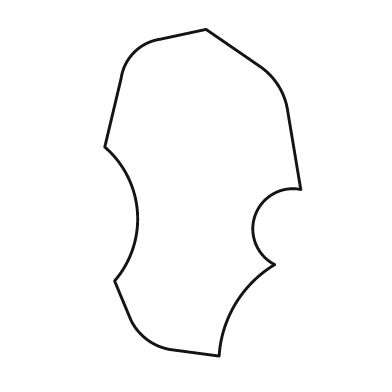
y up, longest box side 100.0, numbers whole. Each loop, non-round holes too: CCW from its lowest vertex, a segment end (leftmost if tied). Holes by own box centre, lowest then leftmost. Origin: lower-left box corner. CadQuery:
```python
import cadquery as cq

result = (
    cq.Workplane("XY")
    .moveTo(35.0, 0.0)
    .threePointArc((40.0, 16.0), (52.0, 28.0))
    .threePointArc((46.0, 43.0), (60.0, 51.0))
    .lineTo(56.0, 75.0)
    .threePointArc((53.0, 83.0), (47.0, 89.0))
    .lineTo(31.0, 100.0)
    .lineTo(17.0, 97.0)
    .threePointArc((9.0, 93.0), (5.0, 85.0))
    .lineTo(0.0, 64.0)
    .threePointArc((10.0, 44.0), (3.0, 23.0))
    .lineTo(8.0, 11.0)
    .threePointArc((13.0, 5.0), (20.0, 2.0))
    .close()
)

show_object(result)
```